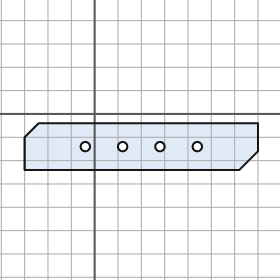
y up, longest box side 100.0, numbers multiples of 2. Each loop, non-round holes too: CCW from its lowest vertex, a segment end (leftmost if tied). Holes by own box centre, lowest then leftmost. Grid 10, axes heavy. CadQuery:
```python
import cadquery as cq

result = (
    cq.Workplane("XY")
    .moveTo(-30.0, -24.0)
    .lineTo(62.0, -24.0)
    .lineTo(70.0, -16.0)
    .lineTo(70.0, -4.0)
    .lineTo(-24.0, -4.0)
    .lineTo(-30.0, -10.0)
    .close()
    .moveTo(-4.0, -14.0)
    .circle(2.0)
    .moveTo(12.0, -14.0)
    .circle(2.0)
    .moveTo(28.0, -14.0)
    .circle(2.0)
    .moveTo(44.0, -14.0)
    .circle(2.0)
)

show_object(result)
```